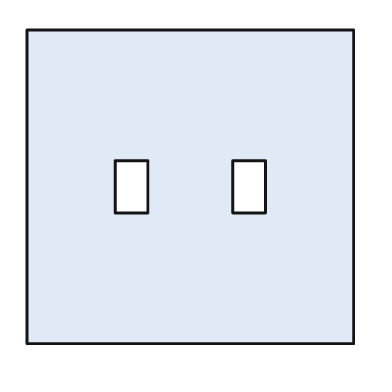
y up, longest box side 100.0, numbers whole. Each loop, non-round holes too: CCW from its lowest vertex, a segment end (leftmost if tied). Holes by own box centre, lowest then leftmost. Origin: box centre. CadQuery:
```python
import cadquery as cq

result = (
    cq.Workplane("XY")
    .moveTo(-50.0, -48.0)
    .lineTo(50.0, -48.0)
    .lineTo(50.0, 48.0)
    .lineTo(-50.0, 48.0)
    .close()
    .moveTo(-23.0, -8.0)
    .lineTo(-13.0, -8.0)
    .lineTo(-13.0, 8.0)
    .lineTo(-23.0, 8.0)
    .close()
    .moveTo(13.0, -8.0)
    .lineTo(23.0, -8.0)
    .lineTo(23.0, 8.0)
    .lineTo(13.0, 8.0)
    .close()
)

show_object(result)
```